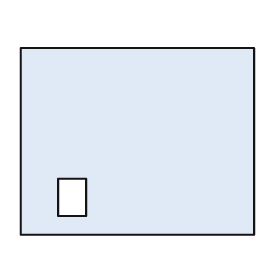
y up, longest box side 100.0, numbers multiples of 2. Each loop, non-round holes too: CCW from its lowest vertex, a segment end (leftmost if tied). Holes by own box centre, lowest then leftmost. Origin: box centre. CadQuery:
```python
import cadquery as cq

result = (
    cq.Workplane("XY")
    .moveTo(-50.0, -40.0)
    .lineTo(50.0, -40.0)
    .lineTo(50.0, 40.0)
    .lineTo(-50.0, 40.0)
    .close()
    .moveTo(-34.0, -32.0)
    .lineTo(-22.0, -32.0)
    .lineTo(-22.0, -16.0)
    .lineTo(-34.0, -16.0)
    .close()
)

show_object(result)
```